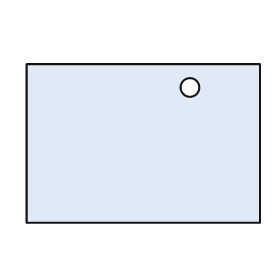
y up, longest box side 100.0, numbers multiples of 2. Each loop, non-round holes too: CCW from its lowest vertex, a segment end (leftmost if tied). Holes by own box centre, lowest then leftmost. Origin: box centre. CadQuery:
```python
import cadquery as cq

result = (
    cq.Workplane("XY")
    .moveTo(-50.0, -34.0)
    .lineTo(50.0, -34.0)
    .lineTo(50.0, 34.0)
    .lineTo(-50.0, 34.0)
    .close()
    .moveTo(20.0, 24.0)
    .circle(4.0)
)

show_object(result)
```